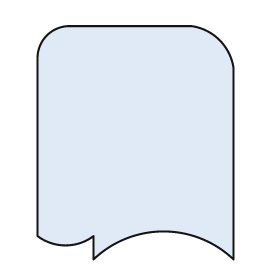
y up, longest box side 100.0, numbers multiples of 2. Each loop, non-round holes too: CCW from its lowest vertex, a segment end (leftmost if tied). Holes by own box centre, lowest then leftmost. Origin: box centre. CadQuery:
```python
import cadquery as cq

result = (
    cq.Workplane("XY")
    .moveTo(-18.0, -50.0)
    .threePointArc((12.0, -38.0), (42.0, -50.0))
    .lineTo(42.0, 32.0)
    .threePointArc((36.0, 44.0), (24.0, 50.0))
    .lineTo(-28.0, 50.0)
    .threePointArc((-38.0, 46.0), (-42.0, 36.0))
    .lineTo(-42.0, -40.0)
    .threePointArc((-30.0, -44.0), (-18.0, -40.0))
    .close()
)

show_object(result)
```